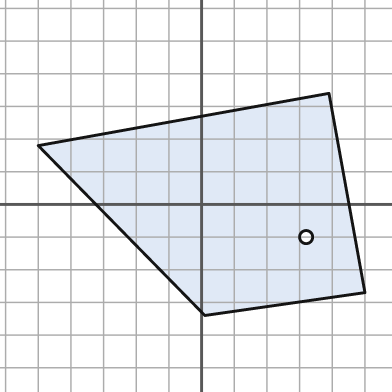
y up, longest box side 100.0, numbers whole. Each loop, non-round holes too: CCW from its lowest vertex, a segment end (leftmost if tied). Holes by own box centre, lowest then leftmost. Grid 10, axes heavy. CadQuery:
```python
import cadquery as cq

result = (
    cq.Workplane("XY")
    .moveTo(1.0, -34.0)
    .lineTo(50.0, -27.0)
    .lineTo(39.0, 34.0)
    .lineTo(-50.0, 18.0)
    .close()
    .moveTo(32.0, -10.0)
    .circle(2.0)
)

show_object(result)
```